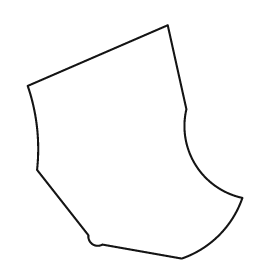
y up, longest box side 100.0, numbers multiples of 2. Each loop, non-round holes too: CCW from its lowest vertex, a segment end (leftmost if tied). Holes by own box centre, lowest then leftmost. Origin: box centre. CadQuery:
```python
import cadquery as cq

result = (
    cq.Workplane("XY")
    .moveTo(20.0, -50.0)
    .threePointArc((36.0, -40.0), (46.0, -24.0))
    .threePointArc((26.0, -10.0), (22.0, 14.0))
    .lineTo(14.0, 50.0)
    .lineTo(-46.0, 24.0)
    .threePointArc((-42.0, 6.0), (-42.0, -12.0))
    .lineTo(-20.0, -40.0)
    .threePointArc((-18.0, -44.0), (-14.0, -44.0))
    .close()
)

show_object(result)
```